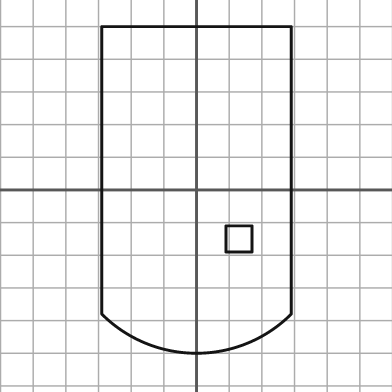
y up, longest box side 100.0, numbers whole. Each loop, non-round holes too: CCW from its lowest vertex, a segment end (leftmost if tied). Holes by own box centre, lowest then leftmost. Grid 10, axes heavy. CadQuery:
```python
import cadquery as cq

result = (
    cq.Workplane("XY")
    .moveTo(-29.0, -38.0)
    .threePointArc((0.0, -50.0), (29.0, -38.0))
    .lineTo(29.0, 50.0)
    .lineTo(-29.0, 50.0)
    .close()
    .moveTo(9.0, -19.0)
    .lineTo(17.0, -19.0)
    .lineTo(17.0, -11.0)
    .lineTo(9.0, -11.0)
    .close()
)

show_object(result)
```